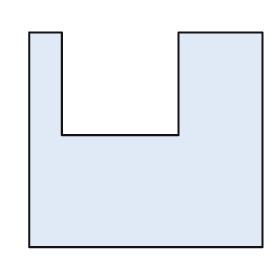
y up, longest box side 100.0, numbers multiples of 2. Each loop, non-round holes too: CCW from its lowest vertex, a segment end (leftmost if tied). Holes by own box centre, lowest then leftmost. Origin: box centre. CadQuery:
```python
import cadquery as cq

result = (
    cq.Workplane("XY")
    .moveTo(-50.0, -46.0)
    .lineTo(50.0, -46.0)
    .lineTo(50.0, 46.0)
    .lineTo(14.0, 46.0)
    .lineTo(14.0, 2.0)
    .lineTo(-36.0, 2.0)
    .lineTo(-36.0, 46.0)
    .lineTo(-50.0, 46.0)
    .close()
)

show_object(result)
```